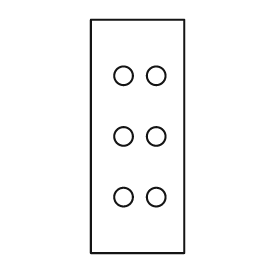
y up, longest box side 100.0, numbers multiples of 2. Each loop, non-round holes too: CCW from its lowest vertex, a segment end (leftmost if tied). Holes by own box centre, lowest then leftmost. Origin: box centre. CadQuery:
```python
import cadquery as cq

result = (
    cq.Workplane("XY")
    .moveTo(-20.0, -50.0)
    .lineTo(20.0, -50.0)
    .lineTo(20.0, 50.0)
    .lineTo(-20.0, 50.0)
    .close()
    .moveTo(-6.0, -26.0)
    .circle(4.0)
    .moveTo(8.0, -26.0)
    .circle(4.0)
    .moveTo(-6.0, 0.0)
    .circle(4.0)
    .moveTo(8.0, 0.0)
    .circle(4.0)
    .moveTo(-6.0, 26.0)
    .circle(4.0)
    .moveTo(8.0, 26.0)
    .circle(4.0)
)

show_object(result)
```